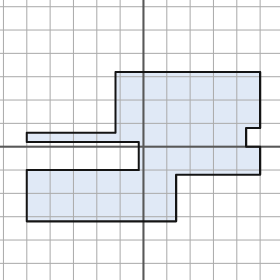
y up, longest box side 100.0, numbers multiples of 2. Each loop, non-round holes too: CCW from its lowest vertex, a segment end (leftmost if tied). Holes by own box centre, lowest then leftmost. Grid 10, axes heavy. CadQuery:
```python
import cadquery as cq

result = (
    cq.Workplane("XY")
    .moveTo(-50.0, -32.0)
    .lineTo(14.0, -32.0)
    .lineTo(14.0, -12.0)
    .lineTo(50.0, -12.0)
    .lineTo(50.0, 0.0)
    .lineTo(44.0, 0.0)
    .lineTo(44.0, 8.0)
    .lineTo(50.0, 8.0)
    .lineTo(50.0, 32.0)
    .lineTo(-12.0, 32.0)
    .lineTo(-12.0, 6.0)
    .lineTo(-50.0, 6.0)
    .lineTo(-50.0, 2.0)
    .lineTo(-2.0, 2.0)
    .lineTo(-2.0, -10.0)
    .lineTo(-50.0, -10.0)
    .close()
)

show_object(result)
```